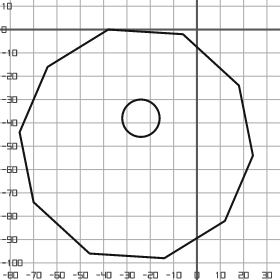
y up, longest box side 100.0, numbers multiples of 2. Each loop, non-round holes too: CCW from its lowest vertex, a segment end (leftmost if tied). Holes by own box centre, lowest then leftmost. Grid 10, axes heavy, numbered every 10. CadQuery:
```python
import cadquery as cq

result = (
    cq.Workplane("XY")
    .moveTo(-14.0, -98.0)
    .lineTo(12.0, -82.0)
    .lineTo(24.0, -54.0)
    .lineTo(18.0, -24.0)
    .lineTo(-6.0, -2.0)
    .lineTo(-38.0, 0.0)
    .lineTo(-64.0, -16.0)
    .lineTo(-76.0, -44.0)
    .lineTo(-70.0, -74.0)
    .lineTo(-46.0, -96.0)
    .close()
    .moveTo(-24.0, -38.0)
    .circle(8.0)
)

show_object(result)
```